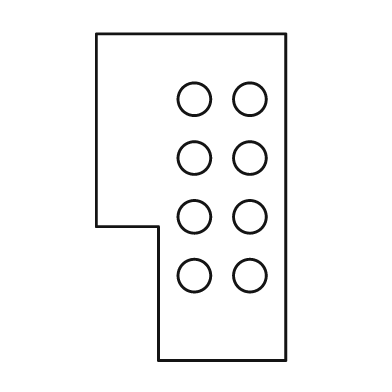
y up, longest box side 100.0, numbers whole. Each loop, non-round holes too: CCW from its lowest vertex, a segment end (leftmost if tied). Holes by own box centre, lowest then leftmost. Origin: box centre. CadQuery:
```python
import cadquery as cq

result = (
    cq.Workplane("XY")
    .moveTo(-10.0, -50.0)
    .lineTo(29.0, -50.0)
    .lineTo(29.0, 50.0)
    .lineTo(-29.0, 50.0)
    .lineTo(-29.0, -9.0)
    .lineTo(-10.0, -9.0)
    .close()
    .moveTo(1.0, -24.0)
    .circle(5.0)
    .moveTo(18.0, -24.0)
    .circle(5.0)
    .moveTo(1.0, -6.0)
    .circle(5.0)
    .moveTo(18.0, -6.0)
    .circle(5.0)
    .moveTo(1.0, 12.0)
    .circle(5.0)
    .moveTo(18.0, 12.0)
    .circle(5.0)
    .moveTo(1.0, 30.0)
    .circle(5.0)
    .moveTo(18.0, 30.0)
    .circle(5.0)
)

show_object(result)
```